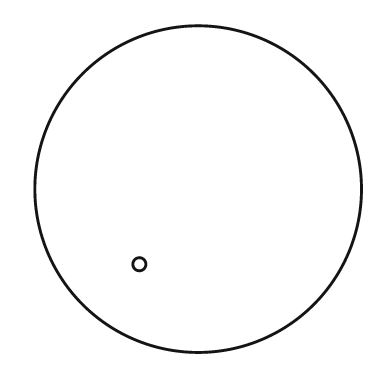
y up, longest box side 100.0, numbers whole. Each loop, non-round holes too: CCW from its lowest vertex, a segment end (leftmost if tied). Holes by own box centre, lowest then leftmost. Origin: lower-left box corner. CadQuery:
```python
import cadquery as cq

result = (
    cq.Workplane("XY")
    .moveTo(50.0, 50.0)
    .circle(50.0)
    .moveTo(32.0, 27.0)
    .circle(2.0)
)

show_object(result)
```